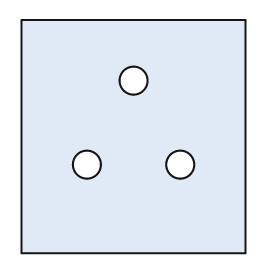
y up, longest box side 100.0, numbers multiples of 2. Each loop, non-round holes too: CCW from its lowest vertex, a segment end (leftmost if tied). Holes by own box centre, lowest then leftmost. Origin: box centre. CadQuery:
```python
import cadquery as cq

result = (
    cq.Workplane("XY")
    .moveTo(-48.0, -50.0)
    .lineTo(48.0, -50.0)
    .lineTo(48.0, 50.0)
    .lineTo(-48.0, 50.0)
    .close()
    .moveTo(-20.0, -12.0)
    .circle(6.0)
    .moveTo(20.0, -12.0)
    .circle(6.0)
    .moveTo(0.0, 24.0)
    .circle(6.0)
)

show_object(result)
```